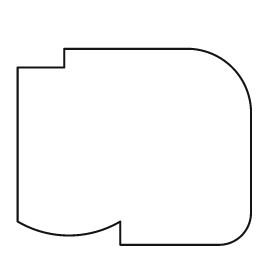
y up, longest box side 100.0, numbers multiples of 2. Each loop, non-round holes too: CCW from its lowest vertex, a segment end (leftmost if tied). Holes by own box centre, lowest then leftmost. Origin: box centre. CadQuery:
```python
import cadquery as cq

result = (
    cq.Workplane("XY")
    .moveTo(-6.0, -42.0)
    .lineTo(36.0, -42.0)
    .threePointArc((46.0, -38.0), (50.0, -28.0))
    .lineTo(50.0, 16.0)
    .threePointArc((42.0, 34.0), (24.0, 42.0))
    .lineTo(-30.0, 42.0)
    .lineTo(-30.0, 34.0)
    .lineTo(-50.0, 34.0)
    .lineTo(-50.0, -32.0)
    .threePointArc((-28.0, -38.0), (-6.0, -32.0))
    .close()
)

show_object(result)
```